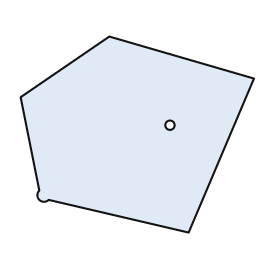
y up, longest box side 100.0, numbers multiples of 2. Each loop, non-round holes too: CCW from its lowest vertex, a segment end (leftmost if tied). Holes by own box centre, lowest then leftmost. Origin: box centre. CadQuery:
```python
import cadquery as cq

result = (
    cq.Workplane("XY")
    .moveTo(22.0, -42.0)
    .lineTo(50.0, 24.0)
    .lineTo(-12.0, 42.0)
    .lineTo(-50.0, 16.0)
    .lineTo(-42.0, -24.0)
    .threePointArc((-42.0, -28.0), (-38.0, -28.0))
    .close()
    .moveTo(14.0, 4.0)
    .circle(2.0)
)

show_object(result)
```